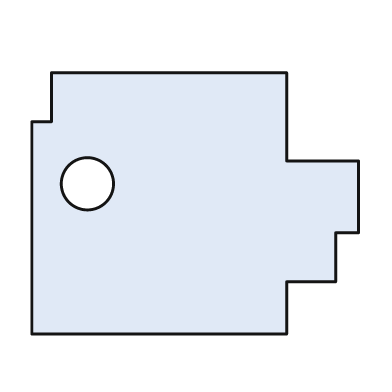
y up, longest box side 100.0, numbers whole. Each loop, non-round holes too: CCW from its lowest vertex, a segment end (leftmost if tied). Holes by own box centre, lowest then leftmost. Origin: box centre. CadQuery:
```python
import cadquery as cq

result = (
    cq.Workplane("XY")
    .moveTo(-50.0, -40.0)
    .lineTo(28.0, -40.0)
    .lineTo(28.0, -24.0)
    .lineTo(43.0, -24.0)
    .lineTo(43.0, -9.0)
    .lineTo(50.0, -9.0)
    .lineTo(50.0, 13.0)
    .lineTo(28.0, 13.0)
    .lineTo(28.0, 40.0)
    .lineTo(-44.0, 40.0)
    .lineTo(-44.0, 25.0)
    .lineTo(-50.0, 25.0)
    .close()
    .moveTo(-33.0, 6.0)
    .circle(8.0)
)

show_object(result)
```